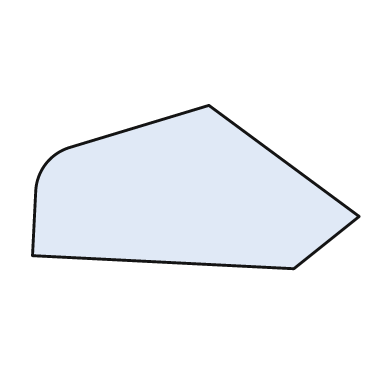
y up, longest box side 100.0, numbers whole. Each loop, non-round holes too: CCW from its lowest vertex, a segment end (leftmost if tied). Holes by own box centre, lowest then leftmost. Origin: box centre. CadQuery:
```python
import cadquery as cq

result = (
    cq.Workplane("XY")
    .moveTo(30.0, -25.0)
    .lineTo(50.0, -9.0)
    .lineTo(4.0, 25.0)
    .lineTo(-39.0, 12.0)
    .threePointArc((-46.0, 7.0), (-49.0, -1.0))
    .lineTo(-50.0, -21.0)
    .close()
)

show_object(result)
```